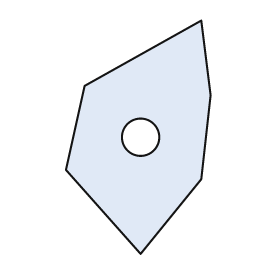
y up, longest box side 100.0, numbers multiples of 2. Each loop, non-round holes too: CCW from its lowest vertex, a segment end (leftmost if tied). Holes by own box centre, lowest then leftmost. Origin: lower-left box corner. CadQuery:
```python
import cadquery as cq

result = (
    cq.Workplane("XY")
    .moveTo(32.0, 0.0)
    .lineTo(58.0, 32.0)
    .lineTo(62.0, 68.0)
    .lineTo(58.0, 100.0)
    .lineTo(8.0, 72.0)
    .lineTo(0.0, 36.0)
    .close()
    .moveTo(32.0, 50.0)
    .circle(8.0)
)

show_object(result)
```